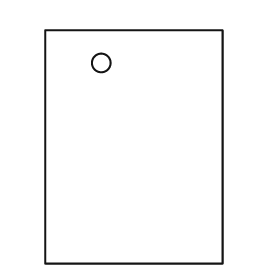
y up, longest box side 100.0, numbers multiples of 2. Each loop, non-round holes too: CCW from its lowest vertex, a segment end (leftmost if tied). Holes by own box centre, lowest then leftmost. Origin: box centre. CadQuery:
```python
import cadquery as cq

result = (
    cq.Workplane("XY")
    .moveTo(-38.0, -50.0)
    .lineTo(38.0, -50.0)
    .lineTo(38.0, 50.0)
    .lineTo(-38.0, 50.0)
    .close()
    .moveTo(-14.0, 36.0)
    .circle(4.0)
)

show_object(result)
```